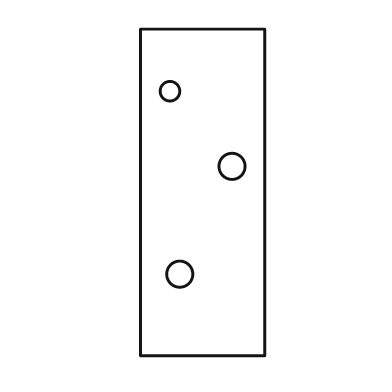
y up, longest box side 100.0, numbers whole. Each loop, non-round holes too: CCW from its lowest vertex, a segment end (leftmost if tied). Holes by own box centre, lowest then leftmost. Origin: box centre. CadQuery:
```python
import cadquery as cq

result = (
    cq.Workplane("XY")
    .moveTo(-19.0, -50.0)
    .lineTo(19.0, -50.0)
    .lineTo(19.0, 50.0)
    .lineTo(-19.0, 50.0)
    .close()
    .moveTo(-7.0, -25.0)
    .circle(4.0)
    .moveTo(9.0, 8.0)
    .circle(4.0)
    .moveTo(-10.0, 31.0)
    .circle(3.0)
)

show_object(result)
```